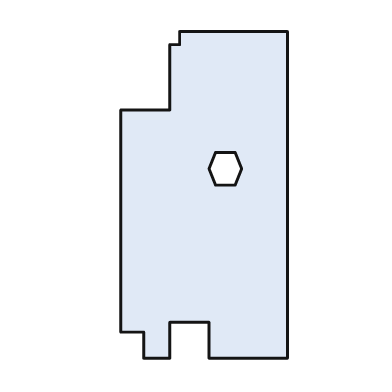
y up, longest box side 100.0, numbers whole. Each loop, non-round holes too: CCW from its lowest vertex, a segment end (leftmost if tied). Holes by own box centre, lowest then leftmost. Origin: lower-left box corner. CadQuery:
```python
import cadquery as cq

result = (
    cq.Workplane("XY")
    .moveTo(7.0, 0.0)
    .lineTo(15.0, 0.0)
    .lineTo(15.0, 11.0)
    .lineTo(27.0, 11.0)
    .lineTo(27.0, 0.0)
    .lineTo(51.0, 0.0)
    .lineTo(51.0, 100.0)
    .lineTo(18.0, 100.0)
    .lineTo(18.0, 96.0)
    .lineTo(15.0, 96.0)
    .lineTo(15.0, 76.0)
    .lineTo(0.0, 76.0)
    .lineTo(0.0, 8.0)
    .lineTo(7.0, 8.0)
    .close()
    .moveTo(29.0, 53.0)
    .lineTo(35.0, 53.0)
    .lineTo(37.0, 58.0)
    .lineTo(35.0, 63.0)
    .lineTo(29.0, 63.0)
    .lineTo(27.0, 58.0)
    .close()
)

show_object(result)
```